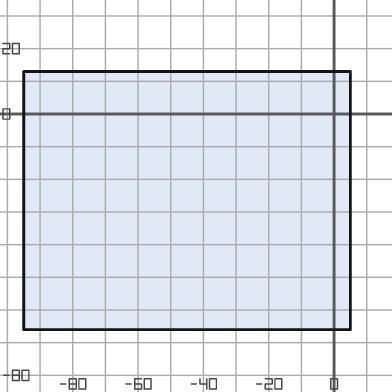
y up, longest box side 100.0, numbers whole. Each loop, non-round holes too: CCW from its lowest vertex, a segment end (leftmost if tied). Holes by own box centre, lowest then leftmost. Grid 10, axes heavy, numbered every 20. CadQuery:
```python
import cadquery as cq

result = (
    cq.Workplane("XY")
    .moveTo(-95.0, -66.0)
    .lineTo(5.0, -66.0)
    .lineTo(5.0, 13.0)
    .lineTo(-95.0, 13.0)
    .close()
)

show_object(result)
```